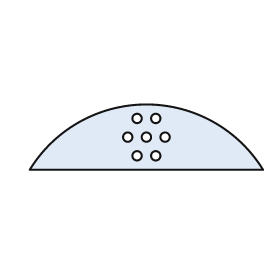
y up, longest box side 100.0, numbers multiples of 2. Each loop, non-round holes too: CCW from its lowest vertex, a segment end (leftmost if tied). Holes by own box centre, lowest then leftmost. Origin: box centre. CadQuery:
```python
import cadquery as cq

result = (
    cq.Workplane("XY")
    .moveTo(-50.0, -14.0)
    .lineTo(50.0, -14.0)
    .threePointArc((0.0, 14.0), (-50.0, -14.0))
    .close()
    .moveTo(-4.0, -8.0)
    .circle(2.0)
    .moveTo(4.0, -8.0)
    .circle(2.0)
    .moveTo(-8.0, 0.0)
    .circle(2.0)
    .moveTo(0.0, 0.0)
    .circle(2.0)
    .moveTo(8.0, 0.0)
    .circle(2.0)
    .moveTo(-4.0, 8.0)
    .circle(2.0)
    .moveTo(4.0, 8.0)
    .circle(2.0)
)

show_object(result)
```